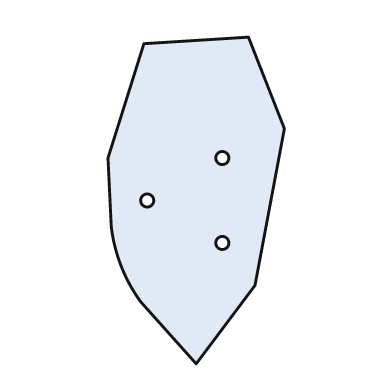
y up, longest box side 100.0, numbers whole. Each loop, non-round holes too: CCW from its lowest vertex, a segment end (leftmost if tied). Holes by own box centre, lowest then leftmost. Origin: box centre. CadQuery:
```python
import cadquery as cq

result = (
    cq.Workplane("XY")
    .moveTo(0.0, -50.0)
    .lineTo(18.0, -26.0)
    .lineTo(27.0, 22.0)
    .lineTo(16.0, 50.0)
    .lineTo(-16.0, 48.0)
    .lineTo(-27.0, 13.0)
    .lineTo(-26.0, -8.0)
    .threePointArc((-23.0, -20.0), (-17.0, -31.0))
    .close()
    .moveTo(8.0, -13.0)
    .circle(2.0)
    .moveTo(-15.0, 0.0)
    .circle(2.0)
    .moveTo(8.0, 13.0)
    .circle(2.0)
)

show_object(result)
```